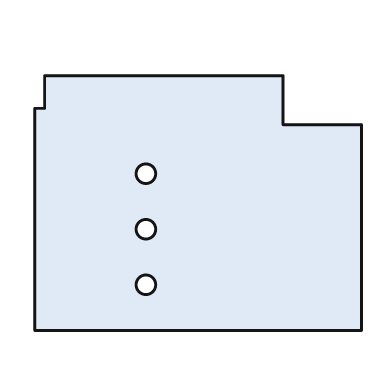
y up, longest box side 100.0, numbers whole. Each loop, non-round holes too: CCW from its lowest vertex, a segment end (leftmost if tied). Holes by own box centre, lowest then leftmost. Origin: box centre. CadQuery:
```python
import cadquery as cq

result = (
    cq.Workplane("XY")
    .moveTo(-50.0, -39.0)
    .lineTo(50.0, -39.0)
    .lineTo(50.0, 24.0)
    .lineTo(26.0, 24.0)
    .lineTo(26.0, 39.0)
    .lineTo(-47.0, 39.0)
    .lineTo(-47.0, 29.0)
    .lineTo(-50.0, 29.0)
    .close()
    .moveTo(-16.0, -25.0)
    .circle(3.0)
    .moveTo(-16.0, -8.0)
    .circle(3.0)
    .moveTo(-16.0, 9.0)
    .circle(3.0)
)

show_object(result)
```